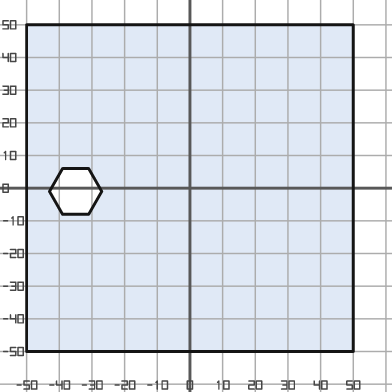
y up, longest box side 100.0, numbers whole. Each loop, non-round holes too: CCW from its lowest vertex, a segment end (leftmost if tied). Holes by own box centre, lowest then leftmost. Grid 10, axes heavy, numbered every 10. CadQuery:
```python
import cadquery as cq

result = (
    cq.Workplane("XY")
    .moveTo(-50.0, -50.0)
    .lineTo(50.0, -50.0)
    .lineTo(50.0, 50.0)
    .lineTo(-50.0, 50.0)
    .close()
    .moveTo(-39.0, -8.0)
    .lineTo(-31.0, -8.0)
    .lineTo(-27.0, -1.0)
    .lineTo(-31.0, 6.0)
    .lineTo(-39.0, 6.0)
    .lineTo(-43.0, -1.0)
    .close()
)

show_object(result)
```